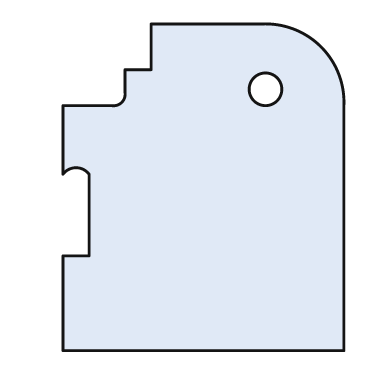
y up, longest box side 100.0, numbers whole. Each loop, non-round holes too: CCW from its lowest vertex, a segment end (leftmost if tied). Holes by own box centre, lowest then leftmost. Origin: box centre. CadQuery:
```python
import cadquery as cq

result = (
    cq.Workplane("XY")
    .moveTo(-43.0, -50.0)
    .lineTo(43.0, -50.0)
    .lineTo(43.0, 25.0)
    .threePointArc((36.0, 43.0), (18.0, 50.0))
    .lineTo(-16.0, 50.0)
    .lineTo(-16.0, 36.0)
    .lineTo(-24.0, 36.0)
    .lineTo(-24.0, 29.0)
    .threePointArc((-25.0, 26.0), (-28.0, 25.0))
    .lineTo(-43.0, 25.0)
    .lineTo(-43.0, 4.0)
    .threePointArc((-39.0, 6.0), (-35.0, 4.0))
    .lineTo(-35.0, -21.0)
    .lineTo(-43.0, -21.0)
    .close()
    .moveTo(19.0, 30.0)
    .circle(5.0)
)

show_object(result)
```